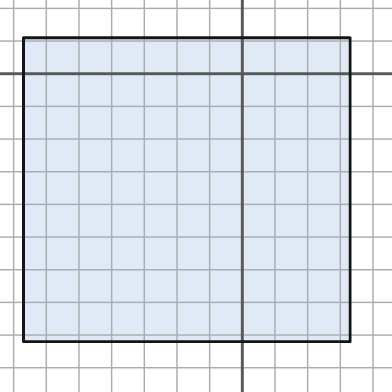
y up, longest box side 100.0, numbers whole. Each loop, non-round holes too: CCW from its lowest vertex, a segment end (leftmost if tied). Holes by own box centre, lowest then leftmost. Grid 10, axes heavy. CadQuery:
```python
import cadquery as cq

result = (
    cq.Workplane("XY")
    .moveTo(-67.0, -82.0)
    .lineTo(33.0, -82.0)
    .lineTo(33.0, 11.0)
    .lineTo(-67.0, 11.0)
    .close()
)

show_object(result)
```